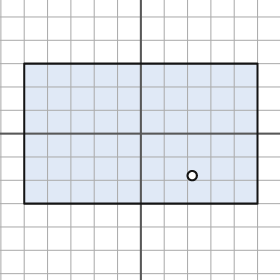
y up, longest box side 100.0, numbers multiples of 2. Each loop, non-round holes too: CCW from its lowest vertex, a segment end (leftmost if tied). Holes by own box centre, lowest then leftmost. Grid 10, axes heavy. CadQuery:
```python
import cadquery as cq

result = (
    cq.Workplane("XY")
    .moveTo(-50.0, -30.0)
    .lineTo(50.0, -30.0)
    .lineTo(50.0, 30.0)
    .lineTo(-50.0, 30.0)
    .close()
    .moveTo(22.0, -18.0)
    .circle(2.0)
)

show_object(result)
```